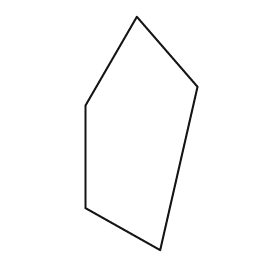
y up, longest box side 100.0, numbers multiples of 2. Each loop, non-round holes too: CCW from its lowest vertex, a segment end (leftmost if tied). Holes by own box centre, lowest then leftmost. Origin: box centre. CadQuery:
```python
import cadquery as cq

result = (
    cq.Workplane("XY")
    .moveTo(8.0, -50.0)
    .lineTo(24.0, 20.0)
    .lineTo(-2.0, 50.0)
    .lineTo(-24.0, 12.0)
    .lineTo(-24.0, -32.0)
    .close()
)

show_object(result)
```